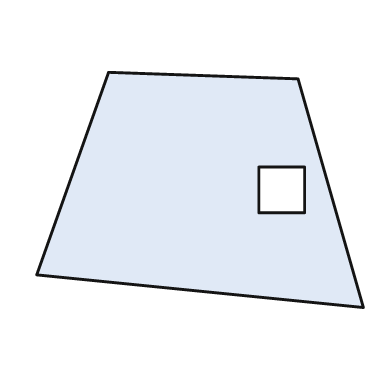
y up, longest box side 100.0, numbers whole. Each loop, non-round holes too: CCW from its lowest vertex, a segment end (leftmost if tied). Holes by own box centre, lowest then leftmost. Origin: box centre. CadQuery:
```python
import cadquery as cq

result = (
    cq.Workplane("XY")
    .moveTo(50.0, -36.0)
    .lineTo(30.0, 34.0)
    .lineTo(-28.0, 36.0)
    .lineTo(-50.0, -26.0)
    .close()
    .moveTo(18.0, -7.0)
    .lineTo(32.0, -7.0)
    .lineTo(32.0, 7.0)
    .lineTo(18.0, 7.0)
    .close()
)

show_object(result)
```